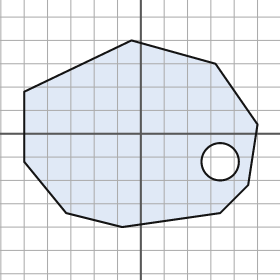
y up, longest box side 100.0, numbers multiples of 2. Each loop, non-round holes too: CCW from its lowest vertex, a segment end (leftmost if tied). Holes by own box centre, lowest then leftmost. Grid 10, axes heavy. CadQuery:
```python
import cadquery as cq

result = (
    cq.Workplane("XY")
    .moveTo(-8.0, -40.0)
    .lineTo(34.0, -34.0)
    .lineTo(46.0, -22.0)
    .lineTo(50.0, 4.0)
    .lineTo(32.0, 30.0)
    .lineTo(-4.0, 40.0)
    .lineTo(-50.0, 18.0)
    .lineTo(-50.0, -12.0)
    .lineTo(-32.0, -34.0)
    .close()
    .moveTo(34.0, -12.0)
    .circle(8.0)
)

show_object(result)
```